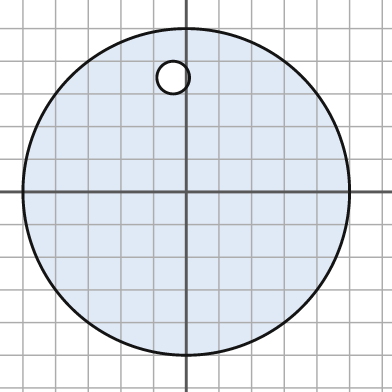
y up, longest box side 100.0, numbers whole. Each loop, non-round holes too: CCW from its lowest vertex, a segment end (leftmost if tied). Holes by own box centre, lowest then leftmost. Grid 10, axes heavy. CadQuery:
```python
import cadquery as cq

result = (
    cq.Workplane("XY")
    .moveTo(0.0, 0.0)
    .circle(50.0)
    .moveTo(-4.0, 35.0)
    .circle(5.0)
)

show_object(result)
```